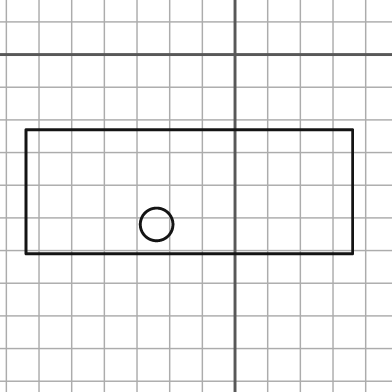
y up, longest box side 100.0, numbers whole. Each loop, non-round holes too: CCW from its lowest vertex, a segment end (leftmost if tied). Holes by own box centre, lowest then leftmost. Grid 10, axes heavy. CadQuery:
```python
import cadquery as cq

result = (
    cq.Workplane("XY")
    .moveTo(-64.0, -61.0)
    .lineTo(36.0, -61.0)
    .lineTo(36.0, -23.0)
    .lineTo(-64.0, -23.0)
    .close()
    .moveTo(-24.0, -52.0)
    .circle(5.0)
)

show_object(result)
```